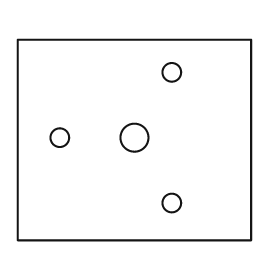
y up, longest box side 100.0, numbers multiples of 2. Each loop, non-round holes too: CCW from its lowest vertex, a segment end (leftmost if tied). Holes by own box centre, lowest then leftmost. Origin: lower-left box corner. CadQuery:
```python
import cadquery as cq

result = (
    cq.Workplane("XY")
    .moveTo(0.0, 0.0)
    .lineTo(100.0, 0.0)
    .lineTo(100.0, 86.0)
    .lineTo(0.0, 86.0)
    .close()
    .moveTo(66.0, 16.0)
    .circle(4.0)
    .moveTo(18.0, 44.0)
    .circle(4.0)
    .moveTo(50.0, 44.0)
    .circle(6.0)
    .moveTo(66.0, 72.0)
    .circle(4.0)
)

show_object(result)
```